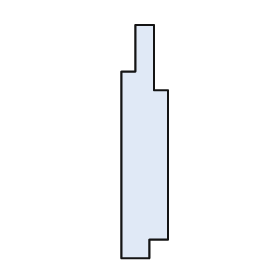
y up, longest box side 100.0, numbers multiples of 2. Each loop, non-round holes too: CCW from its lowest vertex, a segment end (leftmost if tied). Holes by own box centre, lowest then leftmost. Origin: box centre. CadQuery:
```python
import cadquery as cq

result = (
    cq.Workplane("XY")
    .moveTo(-10.0, -50.0)
    .lineTo(2.0, -50.0)
    .lineTo(2.0, -42.0)
    .lineTo(10.0, -42.0)
    .lineTo(10.0, 22.0)
    .lineTo(4.0, 22.0)
    .lineTo(4.0, 50.0)
    .lineTo(-4.0, 50.0)
    .lineTo(-4.0, 30.0)
    .lineTo(-10.0, 30.0)
    .close()
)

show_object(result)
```